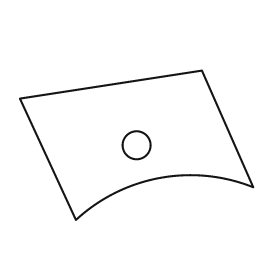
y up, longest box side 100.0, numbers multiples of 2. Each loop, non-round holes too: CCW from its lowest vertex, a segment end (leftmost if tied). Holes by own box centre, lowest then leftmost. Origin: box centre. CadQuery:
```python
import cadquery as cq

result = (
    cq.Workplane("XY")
    .moveTo(-26.0, -32.0)
    .threePointArc((10.0, -14.0), (50.0, -18.0))
    .lineTo(28.0, 32.0)
    .lineTo(-50.0, 20.0)
    .close()
    .moveTo(0.0, 0.0)
    .circle(6.0)
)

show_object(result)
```